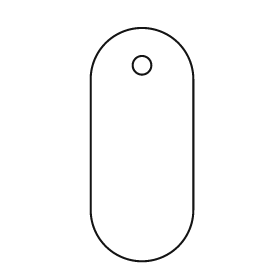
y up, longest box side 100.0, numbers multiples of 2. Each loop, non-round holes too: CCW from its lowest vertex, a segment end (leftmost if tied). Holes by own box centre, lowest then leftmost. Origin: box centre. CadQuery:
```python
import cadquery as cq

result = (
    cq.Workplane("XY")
    .moveTo(-22.0, -28.0)
    .threePointArc((0.0, -50.0), (22.0, -28.0))
    .lineTo(22.0, 28.0)
    .threePointArc((0.0, 50.0), (-22.0, 28.0))
    .close()
    .moveTo(0.0, 34.0)
    .circle(4.0)
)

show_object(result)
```